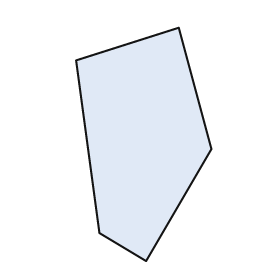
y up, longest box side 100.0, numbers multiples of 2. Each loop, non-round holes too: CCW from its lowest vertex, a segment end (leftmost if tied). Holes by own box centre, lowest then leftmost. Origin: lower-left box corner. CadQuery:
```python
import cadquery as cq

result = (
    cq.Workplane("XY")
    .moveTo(30.0, 0.0)
    .lineTo(58.0, 48.0)
    .lineTo(44.0, 100.0)
    .lineTo(0.0, 86.0)
    .lineTo(10.0, 12.0)
    .close()
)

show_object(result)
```